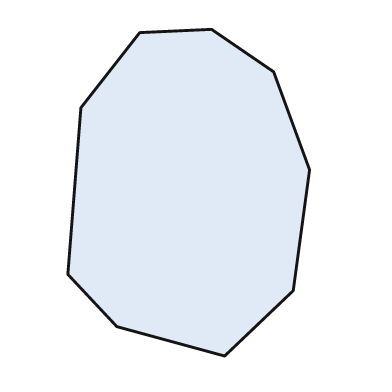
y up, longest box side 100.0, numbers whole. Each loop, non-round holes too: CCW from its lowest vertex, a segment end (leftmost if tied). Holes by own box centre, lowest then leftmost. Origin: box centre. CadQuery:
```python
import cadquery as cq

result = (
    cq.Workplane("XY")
    .moveTo(11.0, -50.0)
    .lineTo(32.0, -30.0)
    .lineTo(37.0, 7.0)
    .lineTo(26.0, 37.0)
    .lineTo(7.0, 50.0)
    .lineTo(-15.0, 49.0)
    .lineTo(-33.0, 26.0)
    .lineTo(-37.0, -25.0)
    .lineTo(-22.0, -41.0)
    .close()
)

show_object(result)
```